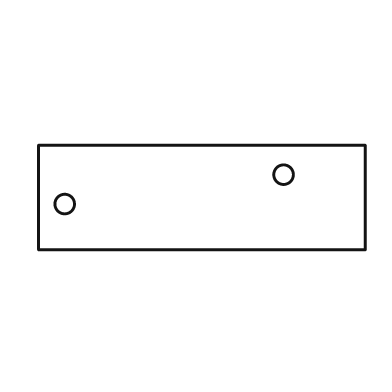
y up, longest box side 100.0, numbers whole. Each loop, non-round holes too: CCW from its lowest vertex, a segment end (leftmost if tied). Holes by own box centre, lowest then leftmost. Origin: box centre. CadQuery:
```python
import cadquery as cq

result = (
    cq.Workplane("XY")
    .moveTo(-50.0, -16.0)
    .lineTo(50.0, -16.0)
    .lineTo(50.0, 16.0)
    .lineTo(-50.0, 16.0)
    .close()
    .moveTo(-42.0, -2.0)
    .circle(3.0)
    .moveTo(25.0, 7.0)
    .circle(3.0)
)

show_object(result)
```